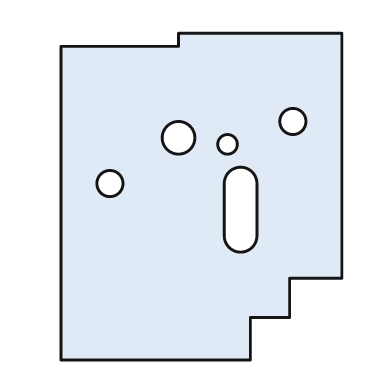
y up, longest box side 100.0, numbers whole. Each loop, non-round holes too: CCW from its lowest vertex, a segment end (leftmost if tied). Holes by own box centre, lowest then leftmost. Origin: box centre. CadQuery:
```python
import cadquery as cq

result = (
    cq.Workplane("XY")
    .moveTo(-43.0, -50.0)
    .lineTo(15.0, -50.0)
    .lineTo(15.0, -37.0)
    .lineTo(27.0, -37.0)
    .lineTo(27.0, -25.0)
    .lineTo(43.0, -25.0)
    .lineTo(43.0, 50.0)
    .lineTo(-7.0, 50.0)
    .lineTo(-7.0, 46.0)
    .lineTo(-43.0, 46.0)
    .close()
    .moveTo(7.0, -12.0)
    .threePointArc((12.0, -17.0), (17.0, -12.0))
    .lineTo(17.0, 4.0)
    .threePointArc((12.0, 9.0), (7.0, 4.0))
    .close()
    .moveTo(-28.0, 4.0)
    .circle(4.0)
    .moveTo(8.0, 16.0)
    .circle(3.0)
    .moveTo(-7.0, 18.0)
    .circle(5.0)
    .moveTo(28.0, 23.0)
    .circle(4.0)
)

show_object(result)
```